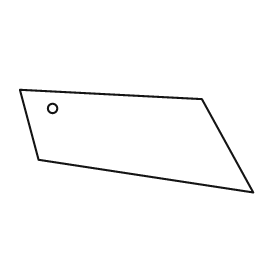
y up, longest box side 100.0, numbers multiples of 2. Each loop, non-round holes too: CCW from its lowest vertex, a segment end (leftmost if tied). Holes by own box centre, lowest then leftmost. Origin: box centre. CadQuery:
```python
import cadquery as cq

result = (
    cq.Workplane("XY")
    .moveTo(50.0, -22.0)
    .lineTo(28.0, 18.0)
    .lineTo(-50.0, 22.0)
    .lineTo(-42.0, -8.0)
    .close()
    .moveTo(-36.0, 14.0)
    .circle(2.0)
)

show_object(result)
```